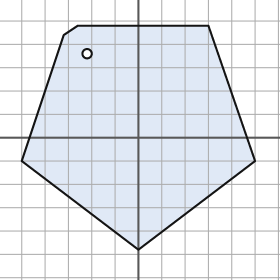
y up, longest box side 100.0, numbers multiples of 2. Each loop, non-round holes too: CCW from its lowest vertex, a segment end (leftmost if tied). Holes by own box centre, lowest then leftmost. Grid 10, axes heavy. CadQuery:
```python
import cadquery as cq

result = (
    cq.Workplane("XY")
    .moveTo(0.0, -48.0)
    .lineTo(50.0, -10.0)
    .lineTo(30.0, 48.0)
    .lineTo(-26.0, 48.0)
    .lineTo(-32.0, 44.0)
    .lineTo(-50.0, -10.0)
    .close()
    .moveTo(-22.0, 36.0)
    .circle(2.0)
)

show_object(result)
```